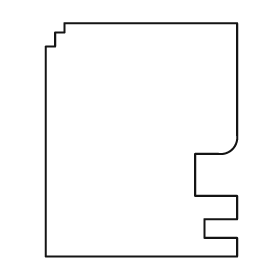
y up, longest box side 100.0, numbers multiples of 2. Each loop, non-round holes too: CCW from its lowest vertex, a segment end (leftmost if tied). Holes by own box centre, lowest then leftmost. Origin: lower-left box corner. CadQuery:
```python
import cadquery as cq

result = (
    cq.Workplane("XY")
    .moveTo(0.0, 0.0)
    .lineTo(82.0, 0.0)
    .lineTo(82.0, 8.0)
    .lineTo(68.0, 8.0)
    .lineTo(68.0, 16.0)
    .lineTo(82.0, 16.0)
    .lineTo(82.0, 26.0)
    .lineTo(64.0, 26.0)
    .lineTo(64.0, 44.0)
    .lineTo(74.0, 44.0)
    .threePointArc((80.0, 46.0), (82.0, 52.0))
    .lineTo(82.0, 100.0)
    .lineTo(8.0, 100.0)
    .lineTo(8.0, 96.0)
    .lineTo(4.0, 96.0)
    .lineTo(4.0, 90.0)
    .lineTo(0.0, 90.0)
    .close()
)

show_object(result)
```